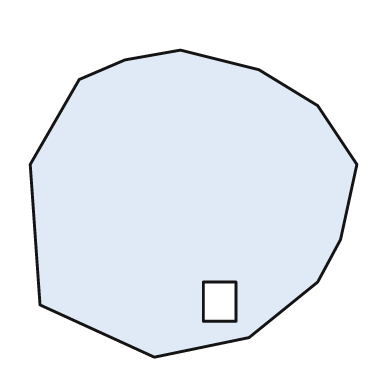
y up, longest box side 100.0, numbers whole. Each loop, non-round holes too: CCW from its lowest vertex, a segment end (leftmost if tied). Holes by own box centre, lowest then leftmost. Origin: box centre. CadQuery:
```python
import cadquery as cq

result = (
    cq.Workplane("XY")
    .moveTo(-12.0, -47.0)
    .lineTo(17.0, -41.0)
    .lineTo(38.0, -24.0)
    .lineTo(45.0, -11.0)
    .lineTo(50.0, 12.0)
    .lineTo(38.0, 30.0)
    .lineTo(20.0, 41.0)
    .lineTo(-4.0, 47.0)
    .lineTo(-21.0, 44.0)
    .lineTo(-35.0, 38.0)
    .lineTo(-50.0, 12.0)
    .lineTo(-47.0, -31.0)
    .close()
    .moveTo(3.0, -36.0)
    .lineTo(13.0, -36.0)
    .lineTo(13.0, -24.0)
    .lineTo(3.0, -24.0)
    .close()
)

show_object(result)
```